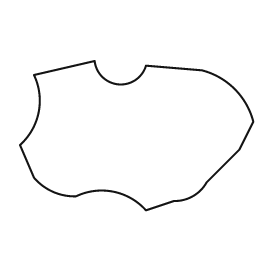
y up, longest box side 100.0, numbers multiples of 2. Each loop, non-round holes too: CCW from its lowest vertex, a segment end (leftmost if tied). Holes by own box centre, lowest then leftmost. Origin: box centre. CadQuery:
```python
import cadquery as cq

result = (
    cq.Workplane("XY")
    .moveTo(4.0, -32.0)
    .lineTo(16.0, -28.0)
    .threePointArc((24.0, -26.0), (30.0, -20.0))
    .lineTo(44.0, -6.0)
    .lineTo(50.0, 6.0)
    .threePointArc((42.0, 20.0), (28.0, 28.0))
    .lineTo(4.0, 30.0)
    .threePointArc((-8.0, 22.0), (-18.0, 32.0))
    .lineTo(-44.0, 26.0)
    .threePointArc((-42.0, 10.0), (-50.0, -4.0))
    .lineTo(-44.0, -18.0)
    .threePointArc((-36.0, -24.0), (-26.0, -26.0))
    .threePointArc((-10.0, -24.0), (4.0, -32.0))
    .close()
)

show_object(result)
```